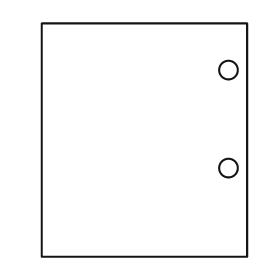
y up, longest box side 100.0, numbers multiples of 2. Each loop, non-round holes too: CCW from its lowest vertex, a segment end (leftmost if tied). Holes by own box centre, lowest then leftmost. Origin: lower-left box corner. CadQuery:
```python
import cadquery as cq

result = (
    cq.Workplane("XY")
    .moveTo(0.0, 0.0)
    .lineTo(88.0, 0.0)
    .lineTo(88.0, 100.0)
    .lineTo(0.0, 100.0)
    .close()
    .moveTo(80.0, 38.0)
    .circle(4.0)
    .moveTo(80.0, 80.0)
    .circle(4.0)
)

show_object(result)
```